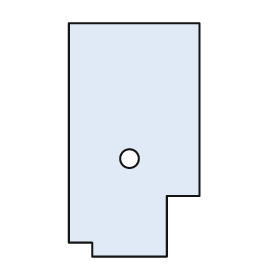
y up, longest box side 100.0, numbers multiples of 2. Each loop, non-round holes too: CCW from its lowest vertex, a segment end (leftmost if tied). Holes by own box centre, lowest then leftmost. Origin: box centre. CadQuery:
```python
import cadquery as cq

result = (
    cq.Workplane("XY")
    .moveTo(-18.0, -50.0)
    .lineTo(14.0, -50.0)
    .lineTo(14.0, -24.0)
    .lineTo(28.0, -24.0)
    .lineTo(28.0, 50.0)
    .lineTo(-28.0, 50.0)
    .lineTo(-28.0, -44.0)
    .lineTo(-18.0, -44.0)
    .close()
    .moveTo(-2.0, -8.0)
    .circle(4.0)
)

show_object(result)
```